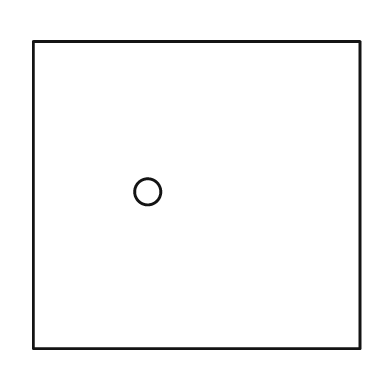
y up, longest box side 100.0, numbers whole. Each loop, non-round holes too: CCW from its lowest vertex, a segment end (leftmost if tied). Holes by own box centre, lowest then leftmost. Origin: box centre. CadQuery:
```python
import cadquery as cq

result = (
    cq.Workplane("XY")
    .moveTo(-50.0, -47.0)
    .lineTo(50.0, -47.0)
    .lineTo(50.0, 47.0)
    .lineTo(-50.0, 47.0)
    .close()
    .moveTo(-15.0, 1.0)
    .circle(4.0)
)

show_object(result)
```